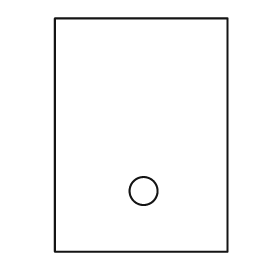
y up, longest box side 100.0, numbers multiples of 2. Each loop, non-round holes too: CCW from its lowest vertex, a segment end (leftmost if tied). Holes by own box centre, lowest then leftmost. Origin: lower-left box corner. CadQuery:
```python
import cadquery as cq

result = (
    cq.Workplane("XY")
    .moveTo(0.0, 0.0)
    .lineTo(74.0, 0.0)
    .lineTo(74.0, 100.0)
    .lineTo(0.0, 100.0)
    .close()
    .moveTo(38.0, 26.0)
    .circle(6.0)
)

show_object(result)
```